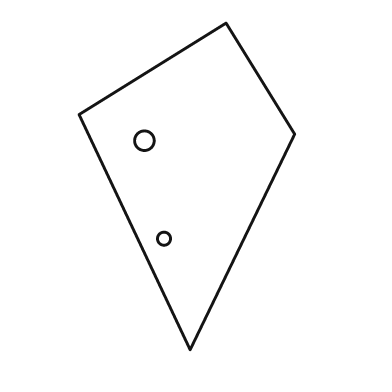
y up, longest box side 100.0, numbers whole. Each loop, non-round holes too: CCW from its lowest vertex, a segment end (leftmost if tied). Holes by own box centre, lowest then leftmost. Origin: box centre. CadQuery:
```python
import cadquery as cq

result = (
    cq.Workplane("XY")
    .moveTo(1.0, -50.0)
    .lineTo(33.0, 16.0)
    .lineTo(12.0, 50.0)
    .lineTo(-33.0, 22.0)
    .close()
    .moveTo(-7.0, -16.0)
    .circle(2.0)
    .moveTo(-13.0, 14.0)
    .circle(3.0)
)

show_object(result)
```